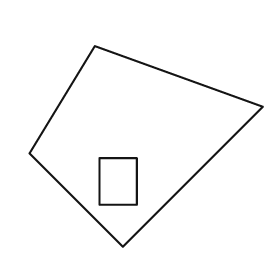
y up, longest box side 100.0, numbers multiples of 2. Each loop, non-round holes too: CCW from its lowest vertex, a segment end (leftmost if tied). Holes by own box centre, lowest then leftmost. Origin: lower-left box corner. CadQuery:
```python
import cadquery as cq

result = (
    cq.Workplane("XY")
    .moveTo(40.0, 0.0)
    .lineTo(100.0, 60.0)
    .lineTo(28.0, 86.0)
    .lineTo(0.0, 40.0)
    .close()
    .moveTo(30.0, 18.0)
    .lineTo(46.0, 18.0)
    .lineTo(46.0, 38.0)
    .lineTo(30.0, 38.0)
    .close()
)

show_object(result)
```